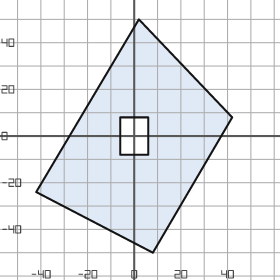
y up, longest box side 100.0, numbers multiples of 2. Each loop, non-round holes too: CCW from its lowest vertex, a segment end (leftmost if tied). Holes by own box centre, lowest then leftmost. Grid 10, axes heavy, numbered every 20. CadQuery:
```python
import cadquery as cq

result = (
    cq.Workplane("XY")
    .moveTo(8.0, -50.0)
    .lineTo(42.0, 8.0)
    .lineTo(2.0, 50.0)
    .lineTo(-42.0, -24.0)
    .close()
    .moveTo(-6.0, -8.0)
    .lineTo(6.0, -8.0)
    .lineTo(6.0, 8.0)
    .lineTo(-6.0, 8.0)
    .close()
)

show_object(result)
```